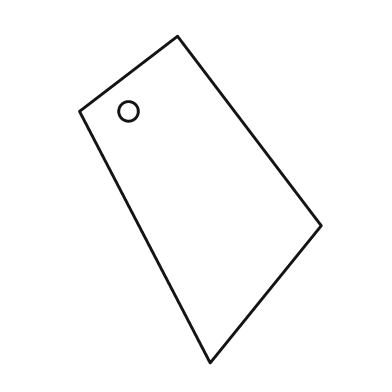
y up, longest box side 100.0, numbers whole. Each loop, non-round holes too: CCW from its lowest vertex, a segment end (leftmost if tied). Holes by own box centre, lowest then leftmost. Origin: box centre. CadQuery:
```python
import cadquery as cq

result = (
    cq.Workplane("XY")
    .moveTo(3.0, -50.0)
    .lineTo(37.0, -8.0)
    .lineTo(-7.0, 50.0)
    .lineTo(-37.0, 27.0)
    .close()
    .moveTo(-22.0, 27.0)
    .circle(3.0)
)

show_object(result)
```